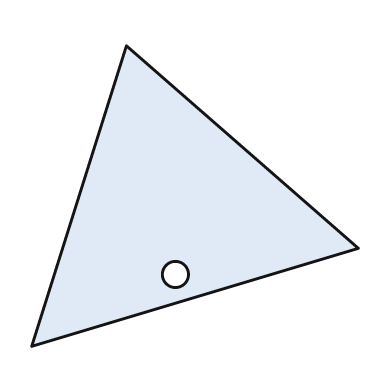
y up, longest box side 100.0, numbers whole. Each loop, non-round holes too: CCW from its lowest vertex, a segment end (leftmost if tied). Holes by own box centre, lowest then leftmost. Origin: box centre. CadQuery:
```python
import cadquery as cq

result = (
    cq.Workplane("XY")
    .moveTo(-50.0, -46.0)
    .lineTo(50.0, -16.0)
    .lineTo(-21.0, 46.0)
    .close()
    .moveTo(-6.0, -24.0)
    .circle(4.0)
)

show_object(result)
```